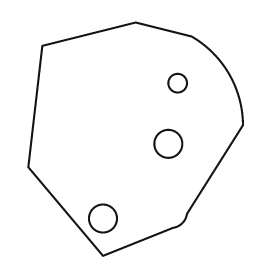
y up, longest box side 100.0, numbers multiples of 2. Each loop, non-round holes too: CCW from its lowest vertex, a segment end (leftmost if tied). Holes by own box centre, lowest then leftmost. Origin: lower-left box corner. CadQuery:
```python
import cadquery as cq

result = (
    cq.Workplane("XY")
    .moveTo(32.0, 0.0)
    .lineTo(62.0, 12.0)
    .threePointArc((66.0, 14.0), (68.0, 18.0))
    .lineTo(92.0, 56.0)
    .threePointArc((86.0, 78.0), (70.0, 94.0))
    .lineTo(46.0, 100.0)
    .lineTo(6.0, 90.0)
    .lineTo(0.0, 38.0)
    .close()
    .moveTo(32.0, 16.0)
    .circle(6.0)
    .moveTo(60.0, 48.0)
    .circle(6.0)
    .moveTo(64.0, 74.0)
    .circle(4.0)
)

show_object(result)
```